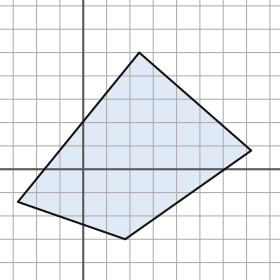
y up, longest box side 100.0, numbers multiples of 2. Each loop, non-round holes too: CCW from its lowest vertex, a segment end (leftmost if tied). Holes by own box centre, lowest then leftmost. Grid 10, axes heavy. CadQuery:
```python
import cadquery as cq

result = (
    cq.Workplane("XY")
    .moveTo(18.0, -30.0)
    .lineTo(72.0, 8.0)
    .lineTo(24.0, 50.0)
    .lineTo(-28.0, -14.0)
    .close()
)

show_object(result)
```